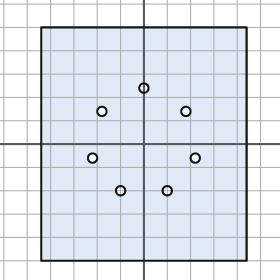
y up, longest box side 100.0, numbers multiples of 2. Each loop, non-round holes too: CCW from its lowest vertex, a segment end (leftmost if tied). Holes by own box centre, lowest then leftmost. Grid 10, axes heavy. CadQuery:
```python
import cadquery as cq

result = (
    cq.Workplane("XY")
    .moveTo(-44.0, -50.0)
    .lineTo(44.0, -50.0)
    .lineTo(44.0, 50.0)
    .lineTo(-44.0, 50.0)
    .close()
    .moveTo(-10.0, -20.0)
    .circle(2.0)
    .moveTo(10.0, -20.0)
    .circle(2.0)
    .moveTo(-22.0, -6.0)
    .circle(2.0)
    .moveTo(22.0, -6.0)
    .circle(2.0)
    .moveTo(-18.0, 14.0)
    .circle(2.0)
    .moveTo(18.0, 14.0)
    .circle(2.0)
    .moveTo(0.0, 24.0)
    .circle(2.0)
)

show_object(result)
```